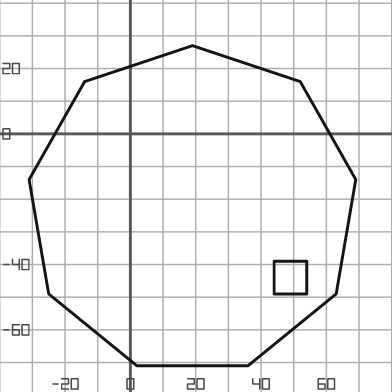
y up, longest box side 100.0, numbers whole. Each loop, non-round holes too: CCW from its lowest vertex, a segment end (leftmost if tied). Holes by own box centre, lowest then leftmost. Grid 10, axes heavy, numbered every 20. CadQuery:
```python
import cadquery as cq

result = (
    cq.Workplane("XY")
    .moveTo(2.0, -71.0)
    .lineTo(36.0, -71.0)
    .lineTo(63.0, -49.0)
    .lineTo(69.0, -14.0)
    .lineTo(52.0, 16.0)
    .lineTo(19.0, 27.0)
    .lineTo(-14.0, 16.0)
    .lineTo(-31.0, -14.0)
    .lineTo(-25.0, -49.0)
    .close()
    .moveTo(44.0, -49.0)
    .lineTo(54.0, -49.0)
    .lineTo(54.0, -39.0)
    .lineTo(44.0, -39.0)
    .close()
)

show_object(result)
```